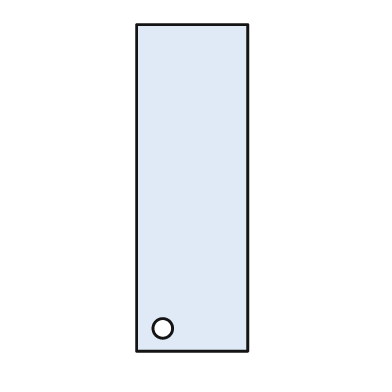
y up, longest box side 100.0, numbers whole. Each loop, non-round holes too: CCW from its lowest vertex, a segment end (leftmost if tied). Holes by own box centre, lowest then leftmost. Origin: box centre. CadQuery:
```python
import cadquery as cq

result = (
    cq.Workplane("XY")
    .moveTo(-17.0, -50.0)
    .lineTo(17.0, -50.0)
    .lineTo(17.0, 50.0)
    .lineTo(-17.0, 50.0)
    .close()
    .moveTo(-9.0, -43.0)
    .circle(3.0)
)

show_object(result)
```